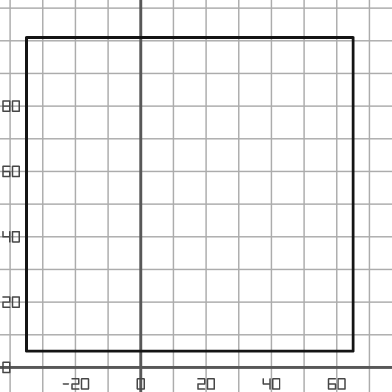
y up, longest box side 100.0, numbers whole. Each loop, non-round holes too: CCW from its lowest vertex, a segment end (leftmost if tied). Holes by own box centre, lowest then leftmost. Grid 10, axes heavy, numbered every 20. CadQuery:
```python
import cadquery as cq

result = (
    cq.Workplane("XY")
    .moveTo(-35.0, 5.0)
    .lineTo(65.0, 5.0)
    .lineTo(65.0, 101.0)
    .lineTo(-35.0, 101.0)
    .close()
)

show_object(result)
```